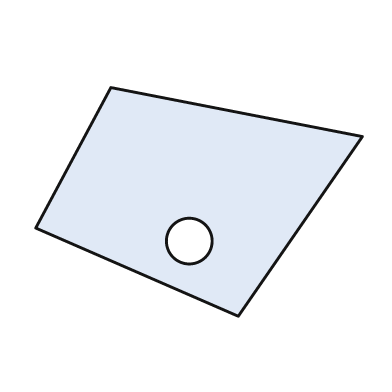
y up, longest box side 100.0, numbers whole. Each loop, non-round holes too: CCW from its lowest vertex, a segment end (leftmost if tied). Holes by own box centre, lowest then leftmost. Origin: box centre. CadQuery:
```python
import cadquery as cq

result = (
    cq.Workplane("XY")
    .moveTo(12.0, -35.0)
    .lineTo(50.0, 20.0)
    .lineTo(-27.0, 35.0)
    .lineTo(-50.0, -8.0)
    .close()
    .moveTo(-3.0, -12.0)
    .circle(7.0)
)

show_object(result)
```